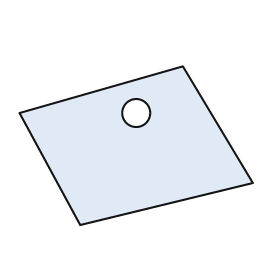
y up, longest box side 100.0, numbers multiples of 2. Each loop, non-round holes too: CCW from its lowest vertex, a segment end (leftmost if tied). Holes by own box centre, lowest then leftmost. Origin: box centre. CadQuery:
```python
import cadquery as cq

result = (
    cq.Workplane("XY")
    .moveTo(-24.0, -34.0)
    .lineTo(50.0, -16.0)
    .lineTo(20.0, 34.0)
    .lineTo(-50.0, 14.0)
    .close()
    .moveTo(0.0, 14.0)
    .circle(6.0)
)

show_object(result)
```